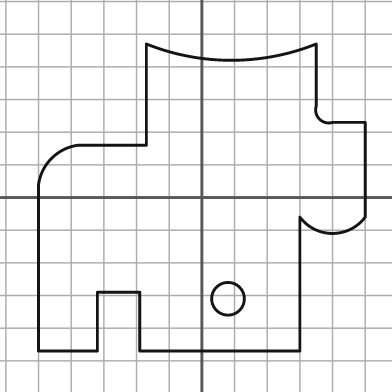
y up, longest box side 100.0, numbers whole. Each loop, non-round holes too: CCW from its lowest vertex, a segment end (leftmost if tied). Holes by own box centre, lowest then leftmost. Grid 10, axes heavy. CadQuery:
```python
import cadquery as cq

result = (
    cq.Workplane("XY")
    .moveTo(-50.0, -47.0)
    .lineTo(-32.0, -47.0)
    .lineTo(-32.0, -29.0)
    .lineTo(-19.0, -29.0)
    .lineTo(-19.0, -47.0)
    .lineTo(30.0, -47.0)
    .lineTo(30.0, -6.0)
    .threePointArc((40.0, -11.0), (50.0, -6.0))
    .lineTo(50.0, 23.0)
    .lineTo(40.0, 23.0)
    .threePointArc((36.0, 24.0), (35.0, 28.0))
    .lineTo(35.0, 47.0)
    .threePointArc((9.0, 42.0), (-17.0, 47.0))
    .lineTo(-17.0, 16.0)
    .lineTo(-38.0, 16.0)
    .threePointArc((-46.0, 12.0), (-50.0, 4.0))
    .close()
    .moveTo(8.0, -31.0)
    .circle(5.0)
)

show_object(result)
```